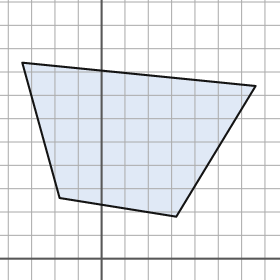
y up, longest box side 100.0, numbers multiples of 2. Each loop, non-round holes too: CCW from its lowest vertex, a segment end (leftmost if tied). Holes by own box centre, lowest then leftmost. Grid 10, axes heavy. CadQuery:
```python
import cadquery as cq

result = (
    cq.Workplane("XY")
    .moveTo(32.0, 18.0)
    .lineTo(66.0, 74.0)
    .lineTo(-34.0, 84.0)
    .lineTo(-18.0, 26.0)
    .close()
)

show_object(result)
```